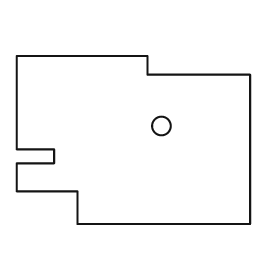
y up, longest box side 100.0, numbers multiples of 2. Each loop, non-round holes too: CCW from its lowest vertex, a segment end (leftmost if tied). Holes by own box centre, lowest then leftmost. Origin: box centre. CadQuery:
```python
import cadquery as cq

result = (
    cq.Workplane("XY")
    .moveTo(-24.0, -36.0)
    .lineTo(50.0, -36.0)
    .lineTo(50.0, 28.0)
    .lineTo(6.0, 28.0)
    .lineTo(6.0, 36.0)
    .lineTo(-50.0, 36.0)
    .lineTo(-50.0, -4.0)
    .lineTo(-34.0, -4.0)
    .lineTo(-34.0, -10.0)
    .lineTo(-50.0, -10.0)
    .lineTo(-50.0, -22.0)
    .lineTo(-24.0, -22.0)
    .close()
    .moveTo(12.0, 6.0)
    .circle(4.0)
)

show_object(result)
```